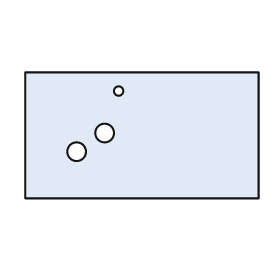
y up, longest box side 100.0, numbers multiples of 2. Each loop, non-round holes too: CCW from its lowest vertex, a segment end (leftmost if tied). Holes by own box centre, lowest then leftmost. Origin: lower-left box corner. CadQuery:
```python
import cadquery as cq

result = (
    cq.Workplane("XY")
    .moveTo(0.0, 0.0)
    .lineTo(100.0, 0.0)
    .lineTo(100.0, 54.0)
    .lineTo(0.0, 54.0)
    .close()
    .moveTo(22.0, 20.0)
    .circle(4.0)
    .moveTo(34.0, 28.0)
    .circle(4.0)
    .moveTo(40.0, 46.0)
    .circle(2.0)
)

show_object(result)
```